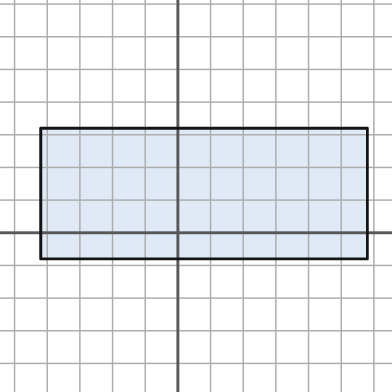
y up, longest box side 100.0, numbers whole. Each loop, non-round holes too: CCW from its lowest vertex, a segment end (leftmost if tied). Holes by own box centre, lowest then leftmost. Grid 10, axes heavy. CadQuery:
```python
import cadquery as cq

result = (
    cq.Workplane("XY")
    .moveTo(-42.0, -8.0)
    .lineTo(58.0, -8.0)
    .lineTo(58.0, 32.0)
    .lineTo(-42.0, 32.0)
    .close()
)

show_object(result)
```